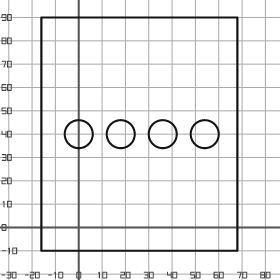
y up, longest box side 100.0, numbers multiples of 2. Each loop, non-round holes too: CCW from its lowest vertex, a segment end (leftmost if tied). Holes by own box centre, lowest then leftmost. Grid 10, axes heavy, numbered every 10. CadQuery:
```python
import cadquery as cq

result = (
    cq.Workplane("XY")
    .moveTo(-16.0, -10.0)
    .lineTo(68.0, -10.0)
    .lineTo(68.0, 90.0)
    .lineTo(-16.0, 90.0)
    .close()
    .moveTo(0.0, 40.0)
    .circle(6.0)
    .moveTo(18.0, 40.0)
    .circle(6.0)
    .moveTo(36.0, 40.0)
    .circle(6.0)
    .moveTo(54.0, 40.0)
    .circle(6.0)
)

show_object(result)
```